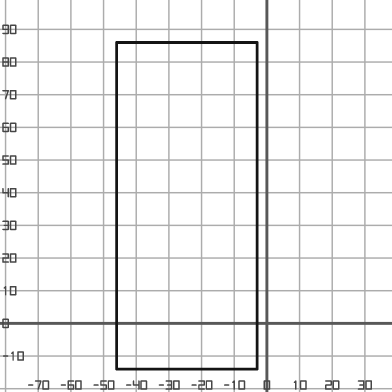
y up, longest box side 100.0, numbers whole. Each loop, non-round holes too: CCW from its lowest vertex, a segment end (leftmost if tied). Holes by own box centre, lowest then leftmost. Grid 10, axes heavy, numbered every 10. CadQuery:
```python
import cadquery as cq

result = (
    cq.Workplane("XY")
    .moveTo(-46.0, -14.0)
    .lineTo(-3.0, -14.0)
    .lineTo(-3.0, 86.0)
    .lineTo(-46.0, 86.0)
    .close()
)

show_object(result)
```